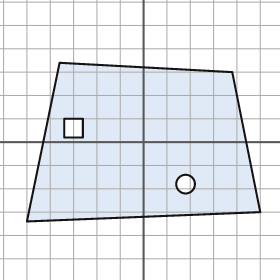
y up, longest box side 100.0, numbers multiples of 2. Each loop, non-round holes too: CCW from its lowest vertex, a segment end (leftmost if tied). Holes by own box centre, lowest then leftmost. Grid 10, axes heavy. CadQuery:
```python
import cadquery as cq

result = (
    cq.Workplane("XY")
    .moveTo(-50.0, -34.0)
    .lineTo(50.0, -30.0)
    .lineTo(38.0, 30.0)
    .lineTo(-36.0, 34.0)
    .close()
    .moveTo(18.0, -18.0)
    .circle(4.0)
    .moveTo(-34.0, 2.0)
    .lineTo(-26.0, 2.0)
    .lineTo(-26.0, 10.0)
    .lineTo(-34.0, 10.0)
    .close()
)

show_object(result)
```